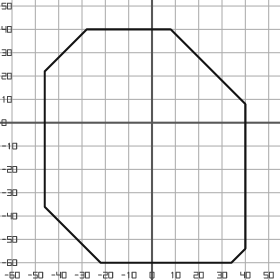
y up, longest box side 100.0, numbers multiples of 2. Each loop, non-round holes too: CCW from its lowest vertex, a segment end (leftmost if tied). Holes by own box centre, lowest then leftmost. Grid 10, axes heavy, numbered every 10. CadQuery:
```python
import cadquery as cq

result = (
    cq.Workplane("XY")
    .moveTo(-22.0, -60.0)
    .lineTo(34.0, -60.0)
    .lineTo(40.0, -54.0)
    .lineTo(40.0, 8.0)
    .lineTo(8.0, 40.0)
    .lineTo(-28.0, 40.0)
    .lineTo(-46.0, 22.0)
    .lineTo(-46.0, -36.0)
    .close()
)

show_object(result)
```